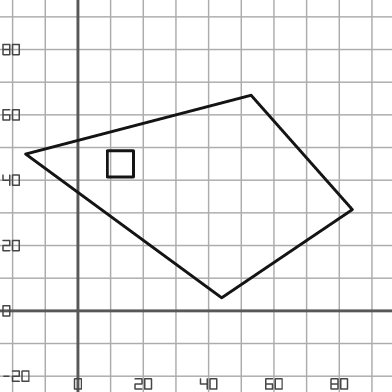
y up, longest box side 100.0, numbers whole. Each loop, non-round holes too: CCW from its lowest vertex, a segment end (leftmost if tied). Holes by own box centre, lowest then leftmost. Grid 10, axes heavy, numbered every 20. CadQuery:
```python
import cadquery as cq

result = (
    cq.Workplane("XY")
    .moveTo(44.0, 4.0)
    .lineTo(84.0, 31.0)
    .lineTo(53.0, 66.0)
    .lineTo(-16.0, 48.0)
    .close()
    .moveTo(9.0, 41.0)
    .lineTo(17.0, 41.0)
    .lineTo(17.0, 49.0)
    .lineTo(9.0, 49.0)
    .close()
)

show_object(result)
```